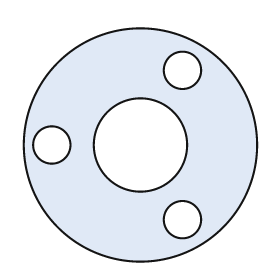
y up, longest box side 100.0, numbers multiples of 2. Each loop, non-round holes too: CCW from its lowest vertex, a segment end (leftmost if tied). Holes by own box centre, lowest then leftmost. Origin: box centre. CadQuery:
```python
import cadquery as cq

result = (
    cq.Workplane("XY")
    .moveTo(0.0, 0.0)
    .circle(50.0)
    .moveTo(18.0, -32.0)
    .circle(8.0)
    .moveTo(-38.0, 0.0)
    .circle(8.0)
    .moveTo(0.0, 0.0)
    .circle(20.0)
    .moveTo(18.0, 32.0)
    .circle(8.0)
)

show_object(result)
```